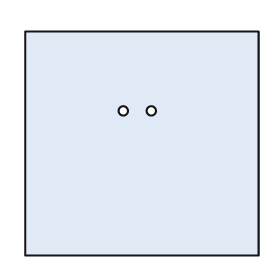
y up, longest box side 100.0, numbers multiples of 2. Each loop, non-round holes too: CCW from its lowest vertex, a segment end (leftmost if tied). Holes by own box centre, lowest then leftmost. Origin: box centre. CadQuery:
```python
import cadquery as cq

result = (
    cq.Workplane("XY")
    .moveTo(-50.0, -48.0)
    .lineTo(50.0, -48.0)
    .lineTo(50.0, 48.0)
    .lineTo(-50.0, 48.0)
    .close()
    .moveTo(-8.0, 14.0)
    .circle(2.0)
    .moveTo(4.0, 14.0)
    .circle(2.0)
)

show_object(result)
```